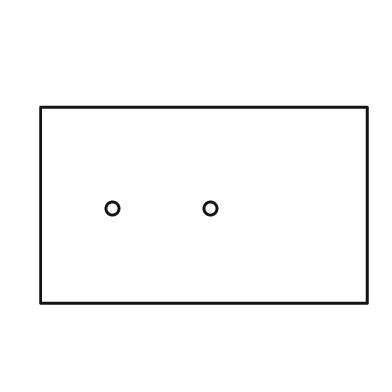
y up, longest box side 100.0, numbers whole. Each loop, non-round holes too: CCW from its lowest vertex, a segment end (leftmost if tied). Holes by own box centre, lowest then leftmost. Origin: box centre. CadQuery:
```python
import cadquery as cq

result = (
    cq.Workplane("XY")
    .moveTo(-50.0, -30.0)
    .lineTo(50.0, -30.0)
    .lineTo(50.0, 30.0)
    .lineTo(-50.0, 30.0)
    .close()
    .moveTo(-28.0, -1.0)
    .circle(2.0)
    .moveTo(2.0, -1.0)
    .circle(2.0)
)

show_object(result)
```